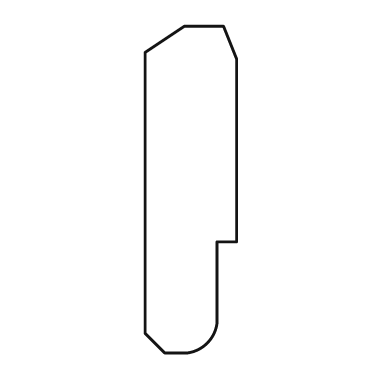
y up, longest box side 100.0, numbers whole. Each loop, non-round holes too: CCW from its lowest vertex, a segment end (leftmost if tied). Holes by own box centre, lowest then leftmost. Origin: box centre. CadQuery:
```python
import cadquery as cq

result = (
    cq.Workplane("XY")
    .moveTo(-8.0, -50.0)
    .lineTo(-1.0, -50.0)
    .threePointArc((5.0, -47.0), (8.0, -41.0))
    .lineTo(8.0, -16.0)
    .lineTo(14.0, -16.0)
    .lineTo(14.0, 40.0)
    .lineTo(10.0, 50.0)
    .lineTo(-2.0, 50.0)
    .lineTo(-14.0, 42.0)
    .lineTo(-14.0, -44.0)
    .close()
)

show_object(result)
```